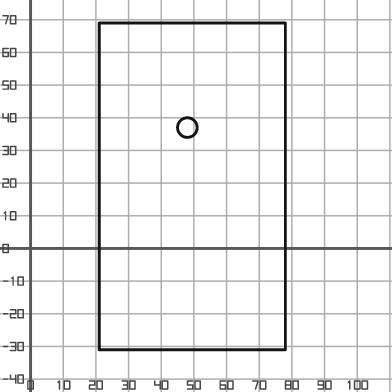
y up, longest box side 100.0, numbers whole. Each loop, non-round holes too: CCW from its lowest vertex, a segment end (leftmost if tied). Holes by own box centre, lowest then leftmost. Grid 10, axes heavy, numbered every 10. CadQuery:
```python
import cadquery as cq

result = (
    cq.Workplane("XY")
    .moveTo(21.0, -31.0)
    .lineTo(78.0, -31.0)
    .lineTo(78.0, 69.0)
    .lineTo(21.0, 69.0)
    .close()
    .moveTo(48.0, 37.0)
    .circle(3.0)
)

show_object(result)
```